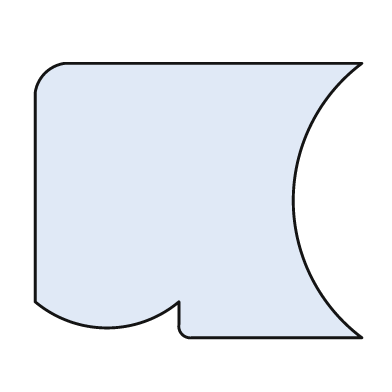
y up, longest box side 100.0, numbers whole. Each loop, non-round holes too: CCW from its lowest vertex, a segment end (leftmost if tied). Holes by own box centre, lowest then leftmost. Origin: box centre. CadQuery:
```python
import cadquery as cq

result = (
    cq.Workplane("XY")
    .moveTo(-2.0, -42.0)
    .lineTo(50.0, -42.0)
    .threePointArc((29.0, 0.0), (50.0, 42.0))
    .lineTo(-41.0, 42.0)
    .threePointArc((-47.0, 39.0), (-50.0, 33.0))
    .lineTo(-50.0, -31.0)
    .threePointArc((-28.0, -39.0), (-6.0, -31.0))
    .lineTo(-6.0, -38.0)
    .threePointArc((-5.0, -41.0), (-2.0, -42.0))
    .close()
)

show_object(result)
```